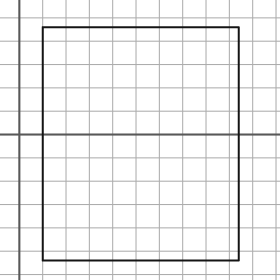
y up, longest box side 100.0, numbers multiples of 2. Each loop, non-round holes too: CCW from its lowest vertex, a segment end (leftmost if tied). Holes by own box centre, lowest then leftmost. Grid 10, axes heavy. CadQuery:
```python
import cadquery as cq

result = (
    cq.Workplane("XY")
    .moveTo(10.0, -54.0)
    .lineTo(94.0, -54.0)
    .lineTo(94.0, 46.0)
    .lineTo(10.0, 46.0)
    .close()
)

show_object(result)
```